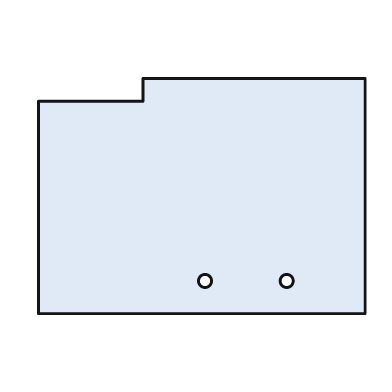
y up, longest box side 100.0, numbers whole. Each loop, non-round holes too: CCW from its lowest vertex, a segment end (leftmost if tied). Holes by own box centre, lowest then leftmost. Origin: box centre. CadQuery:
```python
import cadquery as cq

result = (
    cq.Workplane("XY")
    .moveTo(-50.0, -36.0)
    .lineTo(50.0, -36.0)
    .lineTo(50.0, 36.0)
    .lineTo(-18.0, 36.0)
    .lineTo(-18.0, 29.0)
    .lineTo(-50.0, 29.0)
    .close()
    .moveTo(1.0, -26.0)
    .circle(2.0)
    .moveTo(26.0, -26.0)
    .circle(2.0)
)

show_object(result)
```